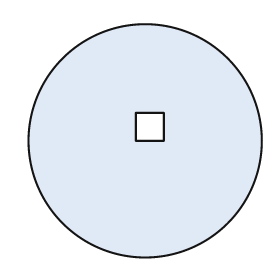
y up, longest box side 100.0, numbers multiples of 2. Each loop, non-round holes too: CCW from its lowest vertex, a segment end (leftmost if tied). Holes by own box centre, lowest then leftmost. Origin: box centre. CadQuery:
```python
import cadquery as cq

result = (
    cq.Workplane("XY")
    .moveTo(0.0, 0.0)
    .circle(50.0)
    .moveTo(-4.0, 0.0)
    .lineTo(8.0, 0.0)
    .lineTo(8.0, 12.0)
    .lineTo(-4.0, 12.0)
    .close()
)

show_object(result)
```